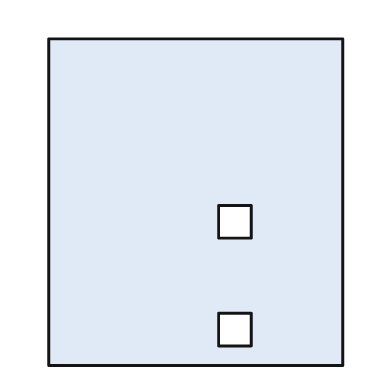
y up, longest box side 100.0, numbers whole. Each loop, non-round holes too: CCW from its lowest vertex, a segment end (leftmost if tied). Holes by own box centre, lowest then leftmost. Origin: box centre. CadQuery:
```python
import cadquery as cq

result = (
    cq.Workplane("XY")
    .moveTo(-45.0, -50.0)
    .lineTo(45.0, -50.0)
    .lineTo(45.0, 50.0)
    .lineTo(-45.0, 50.0)
    .close()
    .moveTo(7.0, -44.0)
    .lineTo(17.0, -44.0)
    .lineTo(17.0, -34.0)
    .lineTo(7.0, -34.0)
    .close()
    .moveTo(7.0, -11.0)
    .lineTo(17.0, -11.0)
    .lineTo(17.0, -1.0)
    .lineTo(7.0, -1.0)
    .close()
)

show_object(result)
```